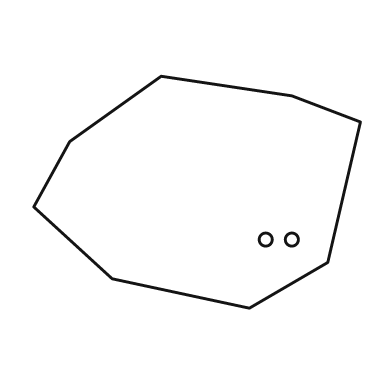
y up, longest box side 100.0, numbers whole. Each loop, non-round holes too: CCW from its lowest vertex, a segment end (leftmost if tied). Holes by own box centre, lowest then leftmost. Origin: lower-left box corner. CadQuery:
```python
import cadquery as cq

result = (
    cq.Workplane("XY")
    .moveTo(66.0, 0.0)
    .lineTo(90.0, 14.0)
    .lineTo(100.0, 57.0)
    .lineTo(79.0, 65.0)
    .lineTo(39.0, 71.0)
    .lineTo(11.0, 51.0)
    .lineTo(0.0, 31.0)
    .lineTo(24.0, 9.0)
    .close()
    .moveTo(71.0, 21.0)
    .circle(2.0)
    .moveTo(79.0, 21.0)
    .circle(2.0)
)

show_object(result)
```